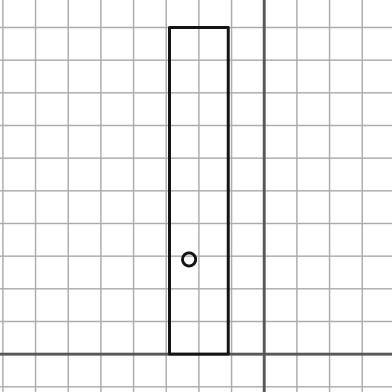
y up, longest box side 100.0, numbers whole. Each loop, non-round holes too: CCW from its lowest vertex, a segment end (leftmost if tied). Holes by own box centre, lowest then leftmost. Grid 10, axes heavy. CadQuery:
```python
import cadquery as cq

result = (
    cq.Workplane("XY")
    .moveTo(-29.0, 0.0)
    .lineTo(-11.0, 0.0)
    .lineTo(-11.0, 100.0)
    .lineTo(-29.0, 100.0)
    .close()
    .moveTo(-23.0, 29.0)
    .circle(2.0)
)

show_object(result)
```